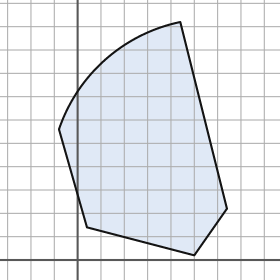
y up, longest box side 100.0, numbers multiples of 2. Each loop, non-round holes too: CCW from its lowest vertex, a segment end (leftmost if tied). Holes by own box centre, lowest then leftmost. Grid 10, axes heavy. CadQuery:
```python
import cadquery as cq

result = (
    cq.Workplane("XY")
    .moveTo(50.0, 2.0)
    .lineTo(64.0, 22.0)
    .lineTo(44.0, 102.0)
    .threePointArc((12.0, 86.0), (-8.0, 56.0))
    .lineTo(4.0, 14.0)
    .close()
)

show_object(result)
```